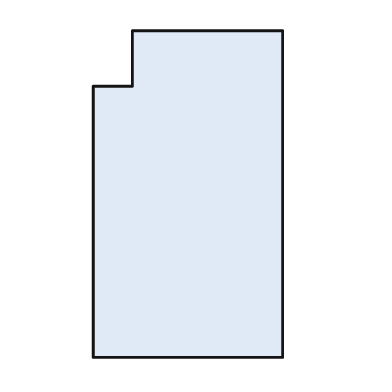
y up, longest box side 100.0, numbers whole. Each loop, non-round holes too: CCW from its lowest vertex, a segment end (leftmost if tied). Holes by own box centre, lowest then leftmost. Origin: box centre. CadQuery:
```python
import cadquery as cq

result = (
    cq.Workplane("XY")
    .moveTo(-29.0, -50.0)
    .lineTo(29.0, -50.0)
    .lineTo(29.0, 50.0)
    .lineTo(-17.0, 50.0)
    .lineTo(-17.0, 33.0)
    .lineTo(-29.0, 33.0)
    .close()
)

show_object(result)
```